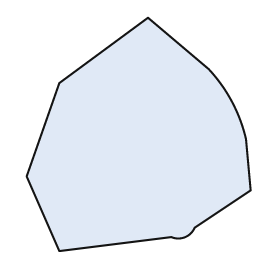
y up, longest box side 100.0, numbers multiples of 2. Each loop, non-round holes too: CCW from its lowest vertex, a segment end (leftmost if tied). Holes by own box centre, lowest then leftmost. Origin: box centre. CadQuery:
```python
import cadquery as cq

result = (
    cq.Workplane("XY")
    .moveTo(-34.0, -50.0)
    .lineTo(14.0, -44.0)
    .threePointArc((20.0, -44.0), (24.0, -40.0))
    .lineTo(48.0, -24.0)
    .lineTo(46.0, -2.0)
    .threePointArc((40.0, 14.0), (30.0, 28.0))
    .lineTo(4.0, 50.0)
    .lineTo(-34.0, 22.0)
    .lineTo(-48.0, -18.0)
    .close()
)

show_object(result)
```